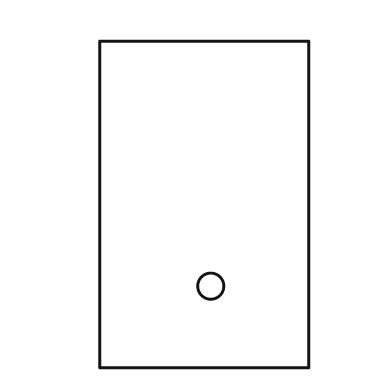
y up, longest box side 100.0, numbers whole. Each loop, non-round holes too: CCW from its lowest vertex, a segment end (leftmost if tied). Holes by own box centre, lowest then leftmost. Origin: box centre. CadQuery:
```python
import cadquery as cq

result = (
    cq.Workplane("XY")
    .moveTo(-32.0, -50.0)
    .lineTo(32.0, -50.0)
    .lineTo(32.0, 50.0)
    .lineTo(-32.0, 50.0)
    .close()
    .moveTo(2.0, -25.0)
    .circle(4.0)
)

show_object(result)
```